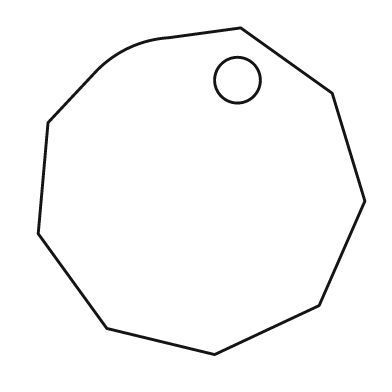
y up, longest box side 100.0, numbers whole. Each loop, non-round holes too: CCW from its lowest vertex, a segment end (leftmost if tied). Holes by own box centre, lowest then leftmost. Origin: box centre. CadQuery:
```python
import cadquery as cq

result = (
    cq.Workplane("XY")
    .moveTo(4.0, -50.0)
    .lineTo(36.0, -35.0)
    .lineTo(50.0, -3.0)
    .lineTo(40.0, 30.0)
    .lineTo(12.0, 50.0)
    .lineTo(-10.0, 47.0)
    .threePointArc((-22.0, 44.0), (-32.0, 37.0))
    .lineTo(-47.0, 21.0)
    .lineTo(-50.0, -13.0)
    .lineTo(-29.0, -42.0)
    .close()
    .moveTo(11.0, 34.0)
    .circle(7.0)
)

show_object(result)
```